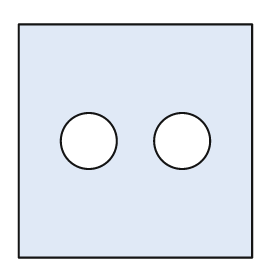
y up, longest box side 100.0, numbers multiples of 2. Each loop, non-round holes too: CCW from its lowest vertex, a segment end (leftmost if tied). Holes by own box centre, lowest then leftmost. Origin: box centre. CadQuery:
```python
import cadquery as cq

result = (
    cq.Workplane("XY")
    .moveTo(-50.0, -50.0)
    .lineTo(50.0, -50.0)
    .lineTo(50.0, 50.0)
    .lineTo(-50.0, 50.0)
    .close()
    .moveTo(-20.0, 0.0)
    .circle(12.0)
    .moveTo(20.0, 0.0)
    .circle(12.0)
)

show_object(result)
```